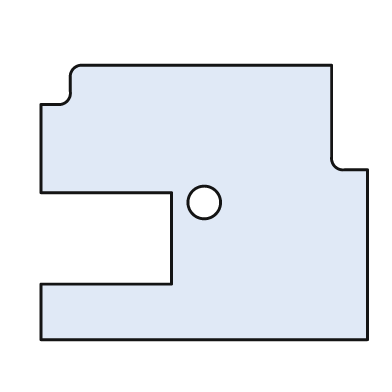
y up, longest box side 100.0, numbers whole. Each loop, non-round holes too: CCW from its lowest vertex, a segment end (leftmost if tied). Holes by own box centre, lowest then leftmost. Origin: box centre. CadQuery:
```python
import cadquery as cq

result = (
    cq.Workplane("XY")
    .moveTo(-50.0, -42.0)
    .lineTo(50.0, -42.0)
    .lineTo(50.0, 10.0)
    .lineTo(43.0, 10.0)
    .threePointArc((40.0, 11.0), (39.0, 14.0))
    .lineTo(39.0, 42.0)
    .lineTo(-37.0, 42.0)
    .threePointArc((-40.0, 41.0), (-41.0, 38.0))
    .lineTo(-41.0, 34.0)
    .threePointArc((-42.0, 31.0), (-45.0, 30.0))
    .lineTo(-50.0, 30.0)
    .lineTo(-50.0, 3.0)
    .lineTo(-10.0, 3.0)
    .lineTo(-10.0, -25.0)
    .lineTo(-50.0, -25.0)
    .close()
    .moveTo(0.0, 0.0)
    .circle(5.0)
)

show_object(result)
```